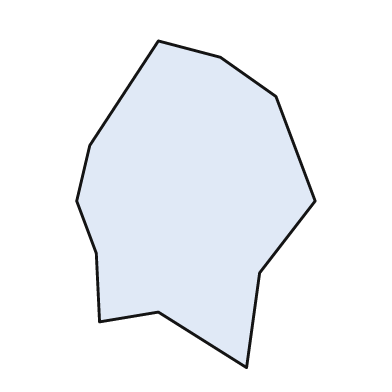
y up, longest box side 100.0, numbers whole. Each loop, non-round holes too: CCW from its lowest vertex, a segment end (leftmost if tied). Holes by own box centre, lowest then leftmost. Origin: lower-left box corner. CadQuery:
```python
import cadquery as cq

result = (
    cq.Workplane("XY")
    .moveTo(52.0, 0.0)
    .lineTo(56.0, 29.0)
    .lineTo(73.0, 51.0)
    .lineTo(61.0, 83.0)
    .lineTo(44.0, 95.0)
    .lineTo(25.0, 100.0)
    .lineTo(4.0, 68.0)
    .lineTo(0.0, 51.0)
    .lineTo(6.0, 35.0)
    .lineTo(7.0, 14.0)
    .lineTo(25.0, 17.0)
    .close()
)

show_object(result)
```